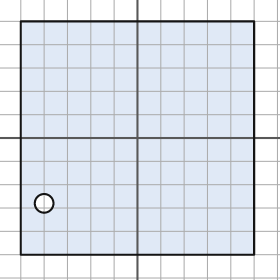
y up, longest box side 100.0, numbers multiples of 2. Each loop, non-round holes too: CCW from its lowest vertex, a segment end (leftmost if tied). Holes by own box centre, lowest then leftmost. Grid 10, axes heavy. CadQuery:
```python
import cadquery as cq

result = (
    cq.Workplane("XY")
    .moveTo(-50.0, -50.0)
    .lineTo(50.0, -50.0)
    .lineTo(50.0, 50.0)
    .lineTo(-50.0, 50.0)
    .close()
    .moveTo(-40.0, -28.0)
    .circle(4.0)
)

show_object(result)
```